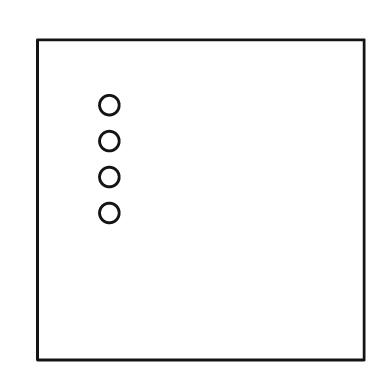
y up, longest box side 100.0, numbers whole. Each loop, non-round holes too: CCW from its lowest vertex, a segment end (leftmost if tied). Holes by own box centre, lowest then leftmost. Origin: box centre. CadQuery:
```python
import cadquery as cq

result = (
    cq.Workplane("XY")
    .moveTo(-50.0, -49.0)
    .lineTo(50.0, -49.0)
    .lineTo(50.0, 49.0)
    .lineTo(-50.0, 49.0)
    .close()
    .moveTo(-28.0, -4.0)
    .circle(3.0)
    .moveTo(-28.0, 7.0)
    .circle(3.0)
    .moveTo(-28.0, 18.0)
    .circle(3.0)
    .moveTo(-28.0, 29.0)
    .circle(3.0)
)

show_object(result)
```